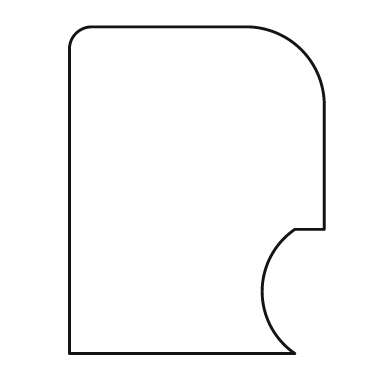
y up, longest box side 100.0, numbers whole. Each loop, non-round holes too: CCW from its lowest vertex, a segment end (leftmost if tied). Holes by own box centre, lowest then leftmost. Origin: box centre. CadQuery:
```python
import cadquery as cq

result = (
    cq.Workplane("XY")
    .moveTo(-39.0, -50.0)
    .lineTo(30.0, -50.0)
    .threePointArc((20.0, -31.0), (30.0, -12.0))
    .lineTo(39.0, -12.0)
    .lineTo(39.0, 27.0)
    .threePointArc((32.0, 43.0), (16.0, 50.0))
    .lineTo(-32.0, 50.0)
    .threePointArc((-37.0, 48.0), (-39.0, 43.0))
    .close()
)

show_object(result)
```